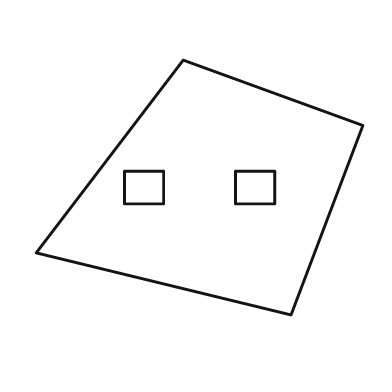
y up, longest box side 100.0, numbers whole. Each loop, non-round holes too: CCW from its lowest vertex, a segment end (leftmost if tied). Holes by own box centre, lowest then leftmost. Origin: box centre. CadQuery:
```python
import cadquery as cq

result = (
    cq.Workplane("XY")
    .moveTo(28.0, -39.0)
    .lineTo(50.0, 19.0)
    .lineTo(-5.0, 39.0)
    .lineTo(-50.0, -20.0)
    .close()
    .moveTo(-23.0, -5.0)
    .lineTo(-11.0, -5.0)
    .lineTo(-11.0, 5.0)
    .lineTo(-23.0, 5.0)
    .close()
    .moveTo(11.0, -5.0)
    .lineTo(23.0, -5.0)
    .lineTo(23.0, 5.0)
    .lineTo(11.0, 5.0)
    .close()
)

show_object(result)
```